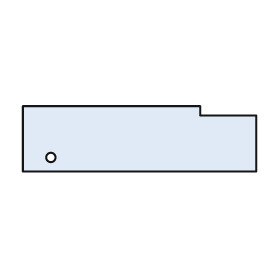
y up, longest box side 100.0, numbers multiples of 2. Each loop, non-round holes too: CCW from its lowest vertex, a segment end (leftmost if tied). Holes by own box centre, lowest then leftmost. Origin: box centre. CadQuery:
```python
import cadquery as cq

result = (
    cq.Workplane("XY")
    .moveTo(-50.0, -14.0)
    .lineTo(50.0, -14.0)
    .lineTo(50.0, 10.0)
    .lineTo(26.0, 10.0)
    .lineTo(26.0, 14.0)
    .lineTo(-50.0, 14.0)
    .close()
    .moveTo(-38.0, -8.0)
    .circle(2.0)
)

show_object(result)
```